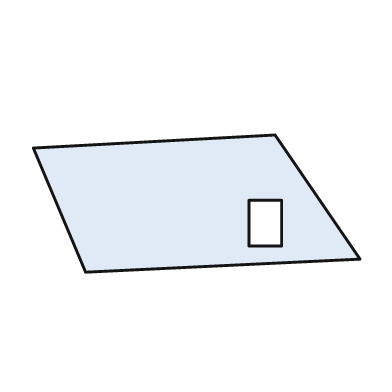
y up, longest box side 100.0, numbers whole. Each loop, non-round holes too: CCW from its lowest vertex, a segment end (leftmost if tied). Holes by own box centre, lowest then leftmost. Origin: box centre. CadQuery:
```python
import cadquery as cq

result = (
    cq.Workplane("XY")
    .moveTo(-34.0, -21.0)
    .lineTo(50.0, -17.0)
    .lineTo(24.0, 21.0)
    .lineTo(-50.0, 17.0)
    .close()
    .moveTo(16.0, -13.0)
    .lineTo(26.0, -13.0)
    .lineTo(26.0, 1.0)
    .lineTo(16.0, 1.0)
    .close()
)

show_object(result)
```